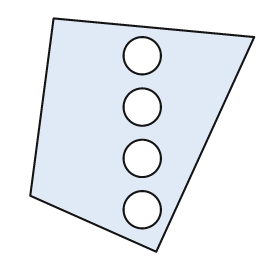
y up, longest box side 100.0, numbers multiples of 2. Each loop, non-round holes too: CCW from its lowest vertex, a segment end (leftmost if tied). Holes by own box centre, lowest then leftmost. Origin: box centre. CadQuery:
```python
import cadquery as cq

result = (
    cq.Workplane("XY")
    .moveTo(6.0, -50.0)
    .lineTo(48.0, 42.0)
    .lineTo(-38.0, 50.0)
    .lineTo(-48.0, -26.0)
    .close()
    .moveTo(0.0, -32.0)
    .circle(8.0)
    .moveTo(0.0, -10.0)
    .circle(8.0)
    .moveTo(0.0, 12.0)
    .circle(8.0)
    .moveTo(0.0, 34.0)
    .circle(8.0)
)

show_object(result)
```